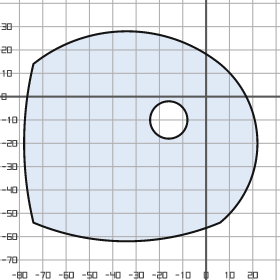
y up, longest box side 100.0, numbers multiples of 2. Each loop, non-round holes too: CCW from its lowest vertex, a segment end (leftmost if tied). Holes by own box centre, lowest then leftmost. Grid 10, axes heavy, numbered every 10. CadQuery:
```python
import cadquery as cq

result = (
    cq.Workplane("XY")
    .moveTo(-74.0, -54.0)
    .threePointArc((-34.0, -62.0), (6.0, -54.0))
    .threePointArc((22.0, -20.0), (6.0, 14.0))
    .threePointArc((-34.0, 28.0), (-74.0, 14.0))
    .threePointArc((-78.0, -20.0), (-74.0, -54.0))
    .close()
    .moveTo(-16.0, -10.0)
    .circle(8.0)
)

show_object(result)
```